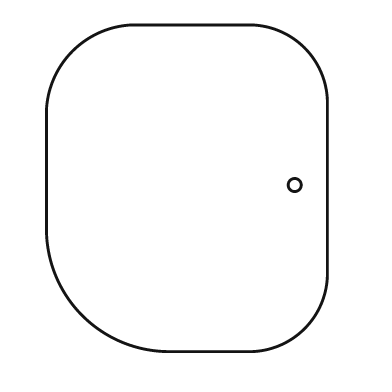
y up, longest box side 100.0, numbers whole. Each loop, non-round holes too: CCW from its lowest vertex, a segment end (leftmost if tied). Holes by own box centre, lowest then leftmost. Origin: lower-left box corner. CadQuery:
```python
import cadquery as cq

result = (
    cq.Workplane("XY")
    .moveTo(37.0, 0.0)
    .lineTo(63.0, 0.0)
    .threePointArc((79.0, 7.0), (86.0, 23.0))
    .lineTo(86.0, 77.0)
    .threePointArc((79.0, 93.0), (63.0, 100.0))
    .lineTo(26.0, 100.0)
    .threePointArc((8.0, 92.0), (0.0, 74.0))
    .lineTo(0.0, 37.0)
    .threePointArc((11.0, 11.0), (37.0, 0.0))
    .close()
    .moveTo(76.0, 51.0)
    .circle(2.0)
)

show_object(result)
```